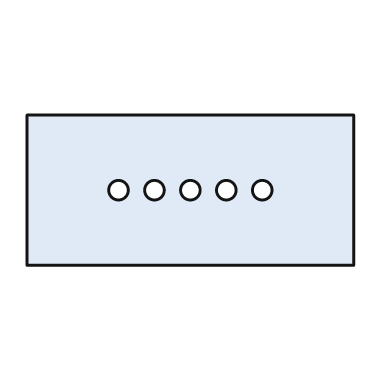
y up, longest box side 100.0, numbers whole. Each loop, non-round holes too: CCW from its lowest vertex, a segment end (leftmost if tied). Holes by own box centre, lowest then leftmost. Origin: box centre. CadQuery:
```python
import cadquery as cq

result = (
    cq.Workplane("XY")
    .moveTo(-50.0, -23.0)
    .lineTo(50.0, -23.0)
    .lineTo(50.0, 23.0)
    .lineTo(-50.0, 23.0)
    .close()
    .moveTo(-22.0, 0.0)
    .circle(3.0)
    .moveTo(-11.0, 0.0)
    .circle(3.0)
    .moveTo(0.0, 0.0)
    .circle(3.0)
    .moveTo(11.0, 0.0)
    .circle(3.0)
    .moveTo(22.0, 0.0)
    .circle(3.0)
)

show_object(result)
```